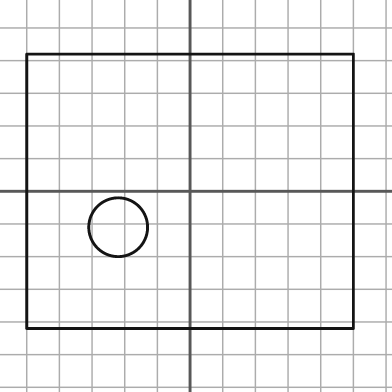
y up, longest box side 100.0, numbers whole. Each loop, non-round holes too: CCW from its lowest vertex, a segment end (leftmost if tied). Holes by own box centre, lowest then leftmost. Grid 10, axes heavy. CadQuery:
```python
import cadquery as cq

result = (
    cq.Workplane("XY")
    .moveTo(-50.0, -42.0)
    .lineTo(50.0, -42.0)
    .lineTo(50.0, 42.0)
    .lineTo(-50.0, 42.0)
    .close()
    .moveTo(-22.0, -11.0)
    .circle(9.0)
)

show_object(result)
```